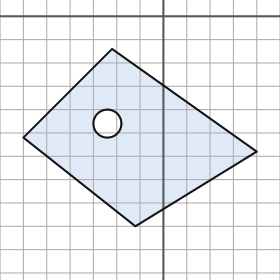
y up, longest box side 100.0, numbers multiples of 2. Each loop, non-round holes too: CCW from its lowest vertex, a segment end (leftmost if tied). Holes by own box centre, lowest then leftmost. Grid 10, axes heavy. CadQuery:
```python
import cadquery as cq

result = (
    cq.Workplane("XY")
    .moveTo(-12.0, -90.0)
    .lineTo(40.0, -58.0)
    .lineTo(-22.0, -14.0)
    .lineTo(-60.0, -52.0)
    .close()
    .moveTo(-24.0, -46.0)
    .circle(6.0)
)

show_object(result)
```